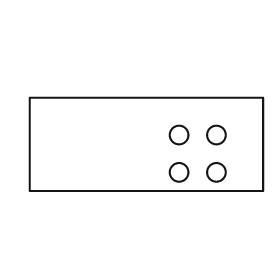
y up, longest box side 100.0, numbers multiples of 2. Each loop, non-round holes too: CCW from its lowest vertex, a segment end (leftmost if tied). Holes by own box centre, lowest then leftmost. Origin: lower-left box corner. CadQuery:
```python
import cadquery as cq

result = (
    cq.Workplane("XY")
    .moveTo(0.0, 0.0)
    .lineTo(100.0, 0.0)
    .lineTo(100.0, 40.0)
    .lineTo(0.0, 40.0)
    .close()
    .moveTo(64.0, 8.0)
    .circle(4.0)
    .moveTo(80.0, 8.0)
    .circle(4.0)
    .moveTo(64.0, 24.0)
    .circle(4.0)
    .moveTo(80.0, 24.0)
    .circle(4.0)
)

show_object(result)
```